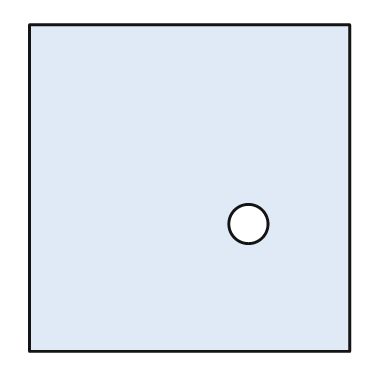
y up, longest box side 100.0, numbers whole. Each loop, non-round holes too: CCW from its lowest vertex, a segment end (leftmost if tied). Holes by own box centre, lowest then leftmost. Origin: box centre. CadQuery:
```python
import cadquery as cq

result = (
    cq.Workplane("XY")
    .moveTo(-49.0, -50.0)
    .lineTo(49.0, -50.0)
    .lineTo(49.0, 50.0)
    .lineTo(-49.0, 50.0)
    .close()
    .moveTo(18.0, -11.0)
    .circle(6.0)
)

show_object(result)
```